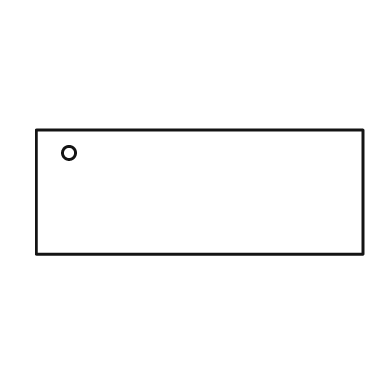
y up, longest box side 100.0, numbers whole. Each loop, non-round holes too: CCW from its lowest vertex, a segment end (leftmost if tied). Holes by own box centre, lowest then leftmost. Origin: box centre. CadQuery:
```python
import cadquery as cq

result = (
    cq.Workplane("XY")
    .moveTo(-50.0, -19.0)
    .lineTo(50.0, -19.0)
    .lineTo(50.0, 19.0)
    .lineTo(-50.0, 19.0)
    .close()
    .moveTo(-40.0, 12.0)
    .circle(2.0)
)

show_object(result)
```